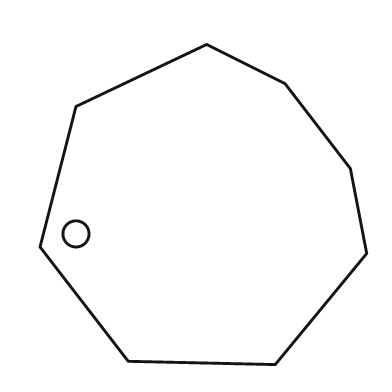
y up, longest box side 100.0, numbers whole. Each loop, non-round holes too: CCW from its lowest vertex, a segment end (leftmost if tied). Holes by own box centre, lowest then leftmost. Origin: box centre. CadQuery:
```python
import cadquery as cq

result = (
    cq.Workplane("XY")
    .moveTo(22.0, -49.0)
    .lineTo(50.0, -15.0)
    .lineTo(45.0, 11.0)
    .lineTo(25.0, 37.0)
    .lineTo(1.0, 49.0)
    .lineTo(-39.0, 30.0)
    .lineTo(-50.0, -13.0)
    .lineTo(-23.0, -48.0)
    .close()
    .moveTo(-39.0, -9.0)
    .circle(4.0)
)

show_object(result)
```